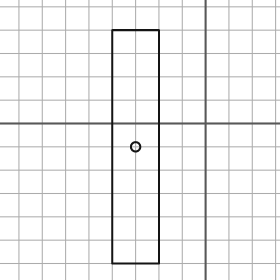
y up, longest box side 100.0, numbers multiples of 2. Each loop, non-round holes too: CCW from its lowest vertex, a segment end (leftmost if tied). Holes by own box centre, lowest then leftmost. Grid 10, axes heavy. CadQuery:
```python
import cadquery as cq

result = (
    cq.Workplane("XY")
    .moveTo(-40.0, -60.0)
    .lineTo(-20.0, -60.0)
    .lineTo(-20.0, 40.0)
    .lineTo(-40.0, 40.0)
    .close()
    .moveTo(-30.0, -10.0)
    .circle(2.0)
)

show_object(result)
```